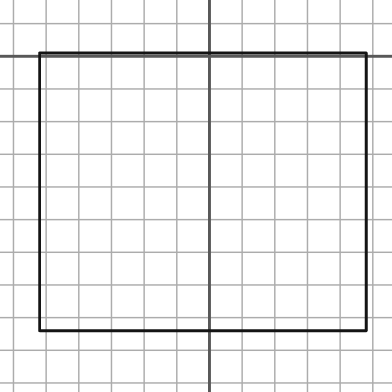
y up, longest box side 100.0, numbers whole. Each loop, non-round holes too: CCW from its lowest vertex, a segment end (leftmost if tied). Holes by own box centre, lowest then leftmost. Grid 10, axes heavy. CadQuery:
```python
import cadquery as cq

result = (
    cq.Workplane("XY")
    .moveTo(-52.0, -84.0)
    .lineTo(48.0, -84.0)
    .lineTo(48.0, 1.0)
    .lineTo(-52.0, 1.0)
    .close()
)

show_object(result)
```